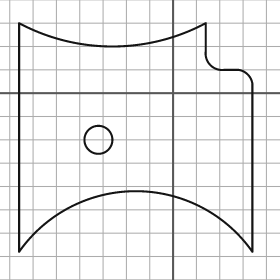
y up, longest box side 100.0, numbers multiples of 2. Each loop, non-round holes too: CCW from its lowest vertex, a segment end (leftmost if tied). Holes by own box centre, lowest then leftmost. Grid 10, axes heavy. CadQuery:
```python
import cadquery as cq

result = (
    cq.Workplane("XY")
    .moveTo(-66.0, -68.0)
    .threePointArc((-16.0, -42.0), (34.0, -68.0))
    .lineTo(34.0, 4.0)
    .threePointArc((32.0, 8.0), (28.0, 10.0))
    .lineTo(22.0, 10.0)
    .threePointArc((16.0, 12.0), (14.0, 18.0))
    .lineTo(14.0, 30.0)
    .threePointArc((-26.0, 20.0), (-66.0, 30.0))
    .close()
    .moveTo(-32.0, -20.0)
    .circle(6.0)
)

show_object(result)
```